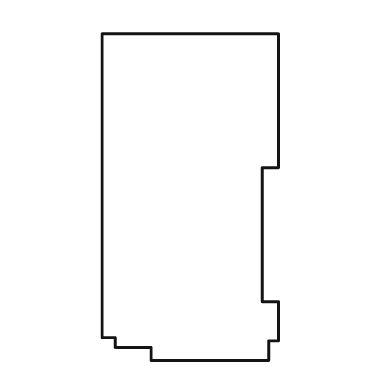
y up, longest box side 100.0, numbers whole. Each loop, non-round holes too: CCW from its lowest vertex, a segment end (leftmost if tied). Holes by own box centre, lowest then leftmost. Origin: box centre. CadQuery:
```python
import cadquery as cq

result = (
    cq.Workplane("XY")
    .moveTo(-12.0, -50.0)
    .lineTo(24.0, -50.0)
    .lineTo(24.0, -44.0)
    .lineTo(27.0, -44.0)
    .lineTo(27.0, -32.0)
    .lineTo(22.0, -32.0)
    .lineTo(22.0, 9.0)
    .lineTo(27.0, 9.0)
    .lineTo(27.0, 50.0)
    .lineTo(-27.0, 50.0)
    .lineTo(-27.0, -43.0)
    .lineTo(-23.0, -43.0)
    .lineTo(-23.0, -46.0)
    .lineTo(-12.0, -46.0)
    .close()
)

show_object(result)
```